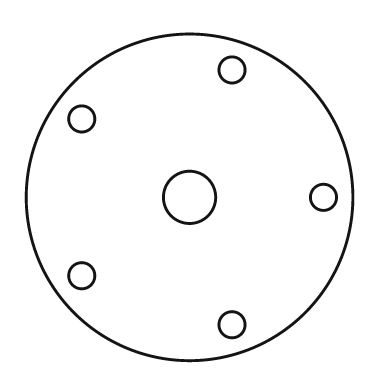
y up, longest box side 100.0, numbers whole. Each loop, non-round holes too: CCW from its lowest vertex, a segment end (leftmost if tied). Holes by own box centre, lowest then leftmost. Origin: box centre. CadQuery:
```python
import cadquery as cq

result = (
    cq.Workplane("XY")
    .moveTo(0.0, 0.0)
    .circle(50.0)
    .moveTo(13.0, -39.0)
    .circle(4.0)
    .moveTo(-33.0, -24.0)
    .circle(4.0)
    .moveTo(0.0, 0.0)
    .circle(8.0)
    .moveTo(41.0, 0.0)
    .circle(4.0)
    .moveTo(-33.0, 24.0)
    .circle(4.0)
    .moveTo(13.0, 39.0)
    .circle(4.0)
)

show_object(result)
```